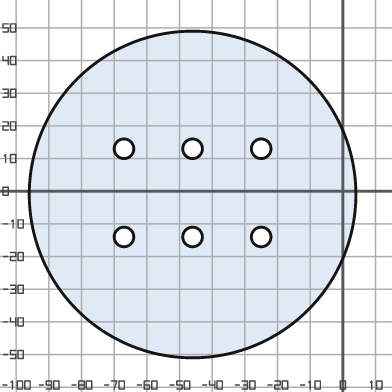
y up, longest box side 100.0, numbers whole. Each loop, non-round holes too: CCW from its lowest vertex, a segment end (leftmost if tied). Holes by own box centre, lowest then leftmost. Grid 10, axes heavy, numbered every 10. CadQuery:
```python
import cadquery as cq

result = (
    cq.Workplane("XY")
    .moveTo(-46.0, -1.0)
    .circle(50.0)
    .moveTo(-67.0, -14.0)
    .circle(3.0)
    .moveTo(-46.0, -14.0)
    .circle(3.0)
    .moveTo(-25.0, -14.0)
    .circle(3.0)
    .moveTo(-67.0, 13.0)
    .circle(3.0)
    .moveTo(-46.0, 13.0)
    .circle(3.0)
    .moveTo(-25.0, 13.0)
    .circle(3.0)
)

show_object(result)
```